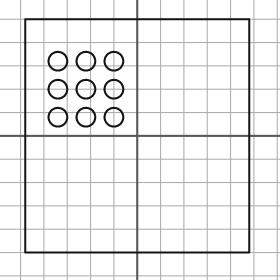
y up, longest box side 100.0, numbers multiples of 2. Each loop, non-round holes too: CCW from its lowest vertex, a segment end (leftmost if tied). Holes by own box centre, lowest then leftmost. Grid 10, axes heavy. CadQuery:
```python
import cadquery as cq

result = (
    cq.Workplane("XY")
    .moveTo(-48.0, -50.0)
    .lineTo(48.0, -50.0)
    .lineTo(48.0, 50.0)
    .lineTo(-48.0, 50.0)
    .close()
    .moveTo(-34.0, 8.0)
    .circle(4.0)
    .moveTo(-22.0, 8.0)
    .circle(4.0)
    .moveTo(-10.0, 8.0)
    .circle(4.0)
    .moveTo(-34.0, 20.0)
    .circle(4.0)
    .moveTo(-22.0, 20.0)
    .circle(4.0)
    .moveTo(-10.0, 20.0)
    .circle(4.0)
    .moveTo(-34.0, 32.0)
    .circle(4.0)
    .moveTo(-22.0, 32.0)
    .circle(4.0)
    .moveTo(-10.0, 32.0)
    .circle(4.0)
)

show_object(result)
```